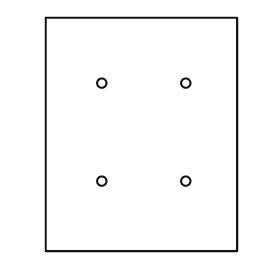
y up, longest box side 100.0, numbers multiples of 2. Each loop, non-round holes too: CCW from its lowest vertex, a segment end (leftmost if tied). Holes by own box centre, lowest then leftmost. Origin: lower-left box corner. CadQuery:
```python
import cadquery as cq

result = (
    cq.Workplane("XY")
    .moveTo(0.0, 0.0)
    .lineTo(82.0, 0.0)
    .lineTo(82.0, 100.0)
    .lineTo(0.0, 100.0)
    .close()
    .moveTo(24.0, 30.0)
    .circle(2.0)
    .moveTo(60.0, 30.0)
    .circle(2.0)
    .moveTo(24.0, 72.0)
    .circle(2.0)
    .moveTo(60.0, 72.0)
    .circle(2.0)
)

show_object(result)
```